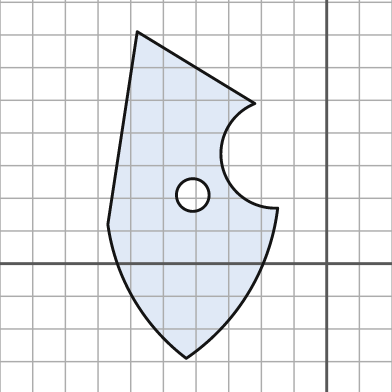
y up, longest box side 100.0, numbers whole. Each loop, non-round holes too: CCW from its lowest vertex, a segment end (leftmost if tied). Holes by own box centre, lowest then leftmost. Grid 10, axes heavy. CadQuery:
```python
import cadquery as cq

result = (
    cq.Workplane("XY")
    .moveTo(-43.0, -29.0)
    .threePointArc((-24.0, -9.0), (-15.0, 17.0))
    .threePointArc((-32.0, 30.0), (-22.0, 49.0))
    .lineTo(-58.0, 71.0)
    .lineTo(-67.0, 12.0)
    .threePointArc((-59.0, -11.0), (-43.0, -29.0))
    .close()
    .moveTo(-41.0, 21.0)
    .circle(5.0)
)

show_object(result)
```